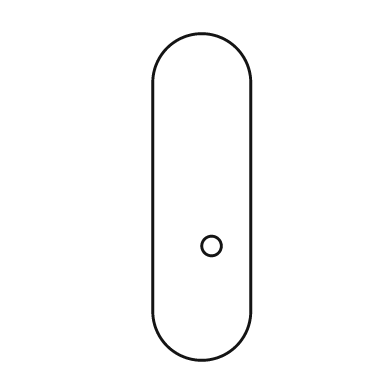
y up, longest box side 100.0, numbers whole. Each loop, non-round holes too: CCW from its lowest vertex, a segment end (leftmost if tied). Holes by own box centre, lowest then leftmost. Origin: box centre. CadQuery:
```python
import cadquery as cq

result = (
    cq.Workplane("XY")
    .moveTo(-15.0, -35.0)
    .threePointArc((0.0, -50.0), (15.0, -35.0))
    .lineTo(15.0, 35.0)
    .threePointArc((0.0, 50.0), (-15.0, 35.0))
    .close()
    .moveTo(3.0, -15.0)
    .circle(3.0)
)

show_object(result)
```